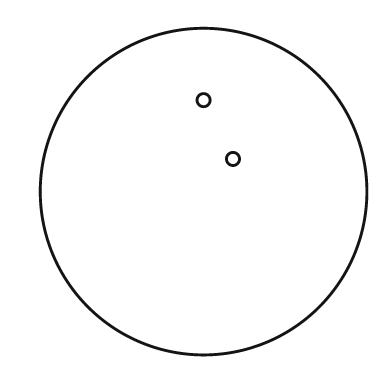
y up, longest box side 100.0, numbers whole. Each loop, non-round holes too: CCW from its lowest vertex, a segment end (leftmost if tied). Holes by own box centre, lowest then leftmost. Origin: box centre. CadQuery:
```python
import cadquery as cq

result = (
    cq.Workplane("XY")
    .moveTo(0.0, 0.0)
    .circle(50.0)
    .moveTo(9.0, 10.0)
    .circle(2.0)
    .moveTo(0.0, 28.0)
    .circle(2.0)
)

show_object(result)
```